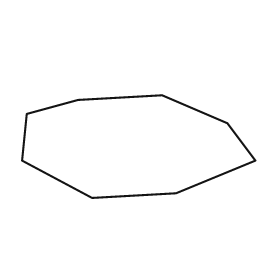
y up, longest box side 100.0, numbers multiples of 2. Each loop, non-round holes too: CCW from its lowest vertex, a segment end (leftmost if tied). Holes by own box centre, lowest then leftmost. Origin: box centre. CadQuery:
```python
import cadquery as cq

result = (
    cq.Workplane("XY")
    .moveTo(-20.0, -22.0)
    .lineTo(16.0, -20.0)
    .lineTo(50.0, -6.0)
    .lineTo(38.0, 10.0)
    .lineTo(10.0, 22.0)
    .lineTo(-26.0, 20.0)
    .lineTo(-48.0, 14.0)
    .lineTo(-50.0, -6.0)
    .close()
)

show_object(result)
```